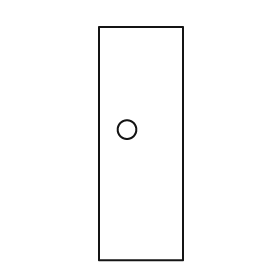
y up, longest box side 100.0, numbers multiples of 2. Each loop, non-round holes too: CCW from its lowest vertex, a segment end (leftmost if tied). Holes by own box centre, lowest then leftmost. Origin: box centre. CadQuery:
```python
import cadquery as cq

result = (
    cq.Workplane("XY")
    .moveTo(-18.0, -50.0)
    .lineTo(18.0, -50.0)
    .lineTo(18.0, 50.0)
    .lineTo(-18.0, 50.0)
    .close()
    .moveTo(-6.0, 6.0)
    .circle(4.0)
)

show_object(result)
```